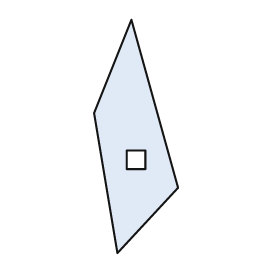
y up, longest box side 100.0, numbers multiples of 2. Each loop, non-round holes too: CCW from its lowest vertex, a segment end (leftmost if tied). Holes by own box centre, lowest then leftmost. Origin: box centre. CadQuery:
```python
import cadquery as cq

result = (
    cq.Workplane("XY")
    .moveTo(-8.0, -50.0)
    .lineTo(18.0, -22.0)
    .lineTo(-2.0, 50.0)
    .lineTo(-18.0, 10.0)
    .close()
    .moveTo(-4.0, -14.0)
    .lineTo(4.0, -14.0)
    .lineTo(4.0, -6.0)
    .lineTo(-4.0, -6.0)
    .close()
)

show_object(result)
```